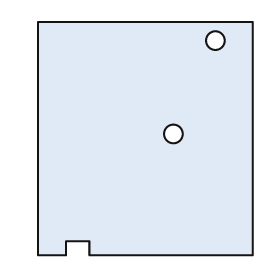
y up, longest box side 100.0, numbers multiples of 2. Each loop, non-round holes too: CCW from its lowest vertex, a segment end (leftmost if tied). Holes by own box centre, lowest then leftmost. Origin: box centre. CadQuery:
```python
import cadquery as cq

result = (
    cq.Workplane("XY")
    .moveTo(-46.0, -50.0)
    .lineTo(-34.0, -50.0)
    .lineTo(-34.0, -44.0)
    .lineTo(-24.0, -44.0)
    .lineTo(-24.0, -50.0)
    .lineTo(46.0, -50.0)
    .lineTo(46.0, 50.0)
    .lineTo(-46.0, 50.0)
    .close()
    .moveTo(12.0, 2.0)
    .circle(4.0)
    .moveTo(30.0, 42.0)
    .circle(4.0)
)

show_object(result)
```